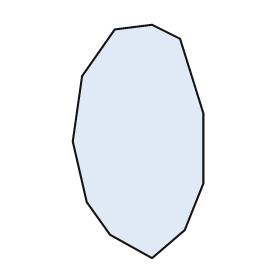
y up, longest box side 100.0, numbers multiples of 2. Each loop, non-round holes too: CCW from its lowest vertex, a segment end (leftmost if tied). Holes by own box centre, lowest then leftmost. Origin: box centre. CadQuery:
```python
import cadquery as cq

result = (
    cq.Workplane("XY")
    .moveTo(6.0, -50.0)
    .lineTo(20.0, -38.0)
    .lineTo(28.0, -18.0)
    .lineTo(28.0, 12.0)
    .lineTo(18.0, 44.0)
    .lineTo(6.0, 50.0)
    .lineTo(-10.0, 48.0)
    .lineTo(-24.0, 28.0)
    .lineTo(-28.0, 0.0)
    .lineTo(-22.0, -26.0)
    .lineTo(-12.0, -40.0)
    .close()
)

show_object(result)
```